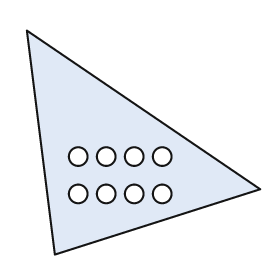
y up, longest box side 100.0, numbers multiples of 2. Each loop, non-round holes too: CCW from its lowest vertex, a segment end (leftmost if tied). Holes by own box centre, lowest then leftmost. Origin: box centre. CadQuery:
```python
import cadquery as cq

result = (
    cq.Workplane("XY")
    .moveTo(-38.0, -48.0)
    .lineTo(50.0, -20.0)
    .lineTo(-50.0, 48.0)
    .close()
    .moveTo(-28.0, -22.0)
    .circle(4.0)
    .moveTo(-16.0, -22.0)
    .circle(4.0)
    .moveTo(-4.0, -22.0)
    .circle(4.0)
    .moveTo(8.0, -22.0)
    .circle(4.0)
    .moveTo(-28.0, -6.0)
    .circle(4.0)
    .moveTo(-16.0, -6.0)
    .circle(4.0)
    .moveTo(-4.0, -6.0)
    .circle(4.0)
    .moveTo(8.0, -6.0)
    .circle(4.0)
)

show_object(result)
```